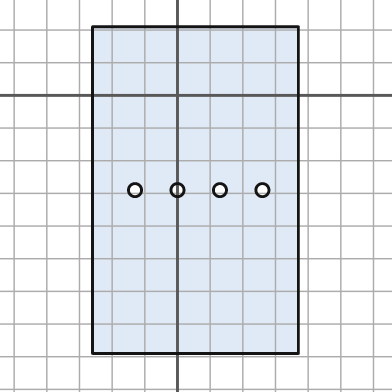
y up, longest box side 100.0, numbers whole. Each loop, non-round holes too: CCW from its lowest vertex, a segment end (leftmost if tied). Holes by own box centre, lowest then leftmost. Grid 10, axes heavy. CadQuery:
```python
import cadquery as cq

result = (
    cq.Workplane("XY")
    .moveTo(-26.0, -79.0)
    .lineTo(37.0, -79.0)
    .lineTo(37.0, 21.0)
    .lineTo(-26.0, 21.0)
    .close()
    .moveTo(-13.0, -29.0)
    .circle(2.0)
    .moveTo(0.0, -29.0)
    .circle(2.0)
    .moveTo(13.0, -29.0)
    .circle(2.0)
    .moveTo(26.0, -29.0)
    .circle(2.0)
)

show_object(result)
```